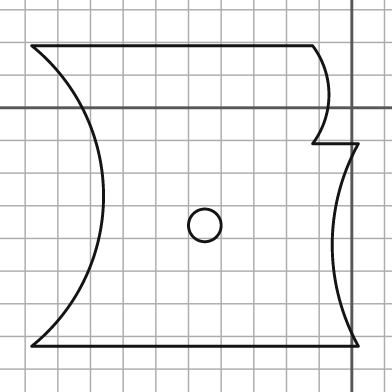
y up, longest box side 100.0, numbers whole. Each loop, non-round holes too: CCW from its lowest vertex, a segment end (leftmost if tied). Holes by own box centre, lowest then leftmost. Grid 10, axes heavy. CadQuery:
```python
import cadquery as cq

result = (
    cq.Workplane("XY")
    .moveTo(-98.0, -73.0)
    .lineTo(2.0, -73.0)
    .threePointArc((-6.0, -42.0), (2.0, -11.0))
    .lineTo(-12.0, -11.0)
    .threePointArc((-7.0, 4.0), (-12.0, 19.0))
    .lineTo(-98.0, 19.0)
    .threePointArc((-76.0, -27.0), (-98.0, -73.0))
    .close()
    .moveTo(-45.0, -36.0)
    .circle(5.0)
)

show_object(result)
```